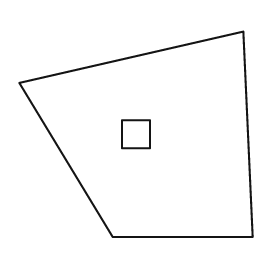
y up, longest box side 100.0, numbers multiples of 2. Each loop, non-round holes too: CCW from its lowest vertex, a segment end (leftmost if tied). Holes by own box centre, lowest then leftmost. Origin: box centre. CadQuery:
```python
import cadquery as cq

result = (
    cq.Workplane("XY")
    .moveTo(-10.0, -44.0)
    .lineTo(50.0, -44.0)
    .lineTo(46.0, 44.0)
    .lineTo(-50.0, 22.0)
    .close()
    .moveTo(-6.0, -6.0)
    .lineTo(6.0, -6.0)
    .lineTo(6.0, 6.0)
    .lineTo(-6.0, 6.0)
    .close()
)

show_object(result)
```